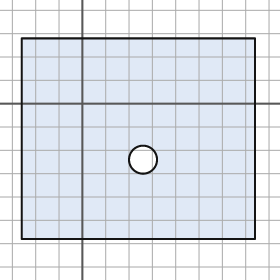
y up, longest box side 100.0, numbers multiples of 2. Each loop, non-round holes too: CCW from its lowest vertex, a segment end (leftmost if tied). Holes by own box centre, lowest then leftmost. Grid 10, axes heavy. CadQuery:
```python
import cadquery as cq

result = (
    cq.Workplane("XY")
    .moveTo(-26.0, -58.0)
    .lineTo(74.0, -58.0)
    .lineTo(74.0, 28.0)
    .lineTo(-26.0, 28.0)
    .close()
    .moveTo(26.0, -24.0)
    .circle(6.0)
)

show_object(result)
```